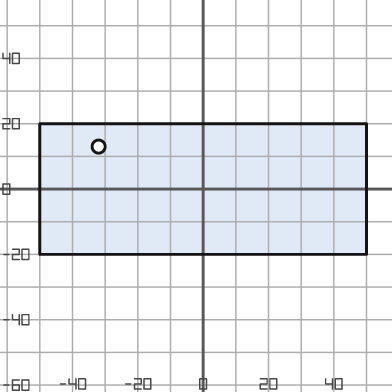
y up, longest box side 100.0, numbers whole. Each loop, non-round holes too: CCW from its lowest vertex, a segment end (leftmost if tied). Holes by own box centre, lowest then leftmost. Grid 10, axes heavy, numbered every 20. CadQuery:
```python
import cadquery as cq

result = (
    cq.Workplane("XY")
    .moveTo(-50.0, -20.0)
    .lineTo(50.0, -20.0)
    .lineTo(50.0, 20.0)
    .lineTo(-50.0, 20.0)
    .close()
    .moveTo(-32.0, 13.0)
    .circle(2.0)
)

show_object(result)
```